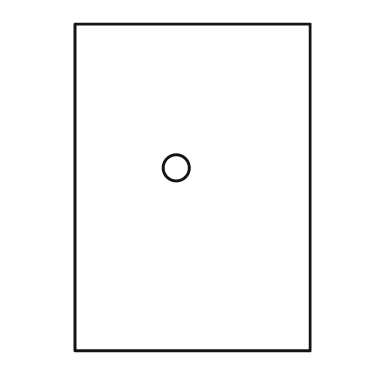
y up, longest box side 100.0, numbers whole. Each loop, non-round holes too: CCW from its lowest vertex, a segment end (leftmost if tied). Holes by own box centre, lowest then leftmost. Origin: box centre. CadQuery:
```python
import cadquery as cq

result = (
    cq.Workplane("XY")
    .moveTo(-36.0, -50.0)
    .lineTo(36.0, -50.0)
    .lineTo(36.0, 50.0)
    .lineTo(-36.0, 50.0)
    .close()
    .moveTo(-5.0, 6.0)
    .circle(4.0)
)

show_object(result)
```